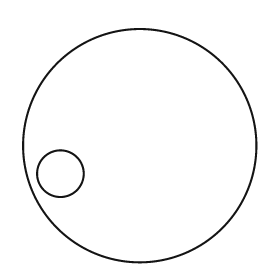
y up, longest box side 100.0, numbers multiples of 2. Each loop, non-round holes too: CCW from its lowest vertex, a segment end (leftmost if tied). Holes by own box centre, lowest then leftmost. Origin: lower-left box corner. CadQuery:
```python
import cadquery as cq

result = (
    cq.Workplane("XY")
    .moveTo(50.0, 50.0)
    .circle(50.0)
    .moveTo(16.0, 38.0)
    .circle(10.0)
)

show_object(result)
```